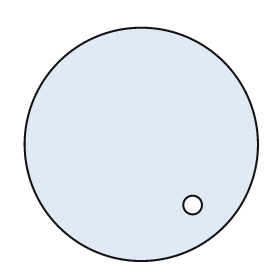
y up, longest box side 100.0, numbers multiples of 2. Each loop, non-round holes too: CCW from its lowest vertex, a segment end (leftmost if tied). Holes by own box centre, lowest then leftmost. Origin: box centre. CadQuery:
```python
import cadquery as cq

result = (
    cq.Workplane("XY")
    .moveTo(0.0, 0.0)
    .circle(50.0)
    .moveTo(22.0, -26.0)
    .circle(4.0)
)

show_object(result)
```